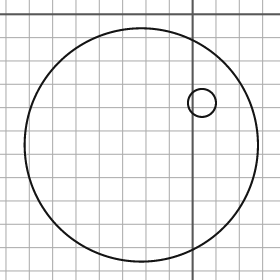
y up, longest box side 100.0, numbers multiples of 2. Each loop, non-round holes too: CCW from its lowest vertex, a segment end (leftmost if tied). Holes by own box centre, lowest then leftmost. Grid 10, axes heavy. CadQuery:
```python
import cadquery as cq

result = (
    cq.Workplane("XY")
    .moveTo(-22.0, -56.0)
    .circle(50.0)
    .moveTo(4.0, -38.0)
    .circle(6.0)
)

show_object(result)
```